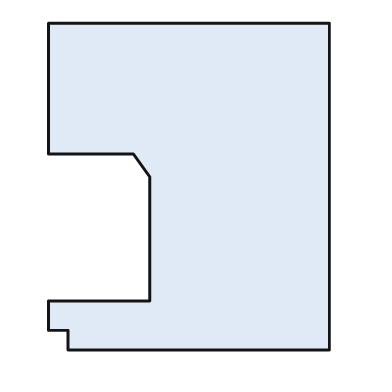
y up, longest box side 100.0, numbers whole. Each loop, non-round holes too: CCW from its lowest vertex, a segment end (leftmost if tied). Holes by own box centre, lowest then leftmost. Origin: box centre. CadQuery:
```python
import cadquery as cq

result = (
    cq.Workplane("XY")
    .moveTo(-37.0, -50.0)
    .lineTo(43.0, -50.0)
    .lineTo(43.0, 50.0)
    .lineTo(-43.0, 50.0)
    .lineTo(-43.0, 10.0)
    .lineTo(-17.0, 10.0)
    .lineTo(-12.0, 3.0)
    .lineTo(-12.0, -35.0)
    .lineTo(-43.0, -35.0)
    .lineTo(-43.0, -44.0)
    .lineTo(-37.0, -44.0)
    .close()
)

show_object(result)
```